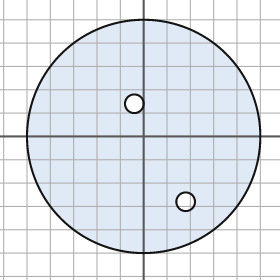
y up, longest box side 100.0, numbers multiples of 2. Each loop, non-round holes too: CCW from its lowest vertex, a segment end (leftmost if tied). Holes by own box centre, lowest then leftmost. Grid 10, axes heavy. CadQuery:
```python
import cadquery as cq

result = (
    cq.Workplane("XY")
    .moveTo(0.0, 0.0)
    .circle(50.0)
    .moveTo(18.0, -28.0)
    .circle(4.0)
    .moveTo(-4.0, 14.0)
    .circle(4.0)
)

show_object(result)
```